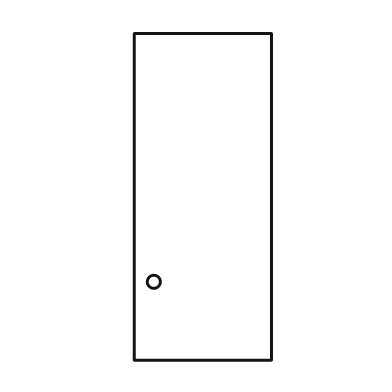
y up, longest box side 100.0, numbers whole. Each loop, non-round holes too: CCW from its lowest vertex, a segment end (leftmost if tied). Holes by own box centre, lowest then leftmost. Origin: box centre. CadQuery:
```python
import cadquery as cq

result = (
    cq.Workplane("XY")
    .moveTo(-21.0, -50.0)
    .lineTo(21.0, -50.0)
    .lineTo(21.0, 50.0)
    .lineTo(-21.0, 50.0)
    .close()
    .moveTo(-15.0, -26.0)
    .circle(2.0)
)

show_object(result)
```